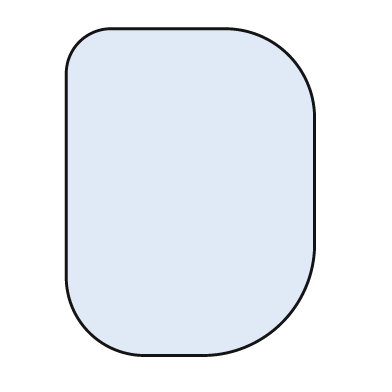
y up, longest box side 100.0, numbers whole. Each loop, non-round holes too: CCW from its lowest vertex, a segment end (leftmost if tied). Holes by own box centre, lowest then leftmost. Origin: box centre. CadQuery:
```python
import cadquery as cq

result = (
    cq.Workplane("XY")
    .moveTo(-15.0, -50.0)
    .lineTo(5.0, -50.0)
    .threePointArc((28.0, -40.0), (38.0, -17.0))
    .lineTo(38.0, 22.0)
    .threePointArc((30.0, 42.0), (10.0, 50.0))
    .lineTo(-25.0, 50.0)
    .threePointArc((-34.0, 46.0), (-38.0, 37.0))
    .lineTo(-38.0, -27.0)
    .threePointArc((-31.0, -43.0), (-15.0, -50.0))
    .close()
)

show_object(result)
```